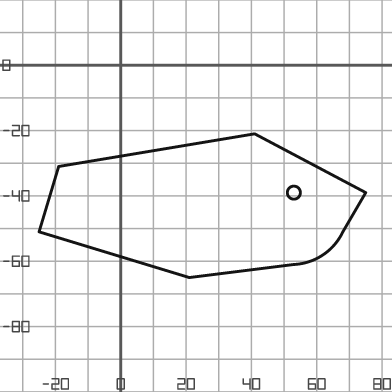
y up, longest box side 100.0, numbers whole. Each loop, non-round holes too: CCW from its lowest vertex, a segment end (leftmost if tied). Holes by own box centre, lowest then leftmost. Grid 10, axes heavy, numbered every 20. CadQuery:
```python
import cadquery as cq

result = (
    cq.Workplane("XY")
    .moveTo(21.0, -65.0)
    .lineTo(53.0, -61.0)
    .threePointArc((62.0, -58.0), (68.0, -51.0))
    .lineTo(75.0, -39.0)
    .lineTo(41.0, -21.0)
    .lineTo(-19.0, -31.0)
    .lineTo(-25.0, -51.0)
    .close()
    .moveTo(53.0, -39.0)
    .circle(2.0)
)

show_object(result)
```